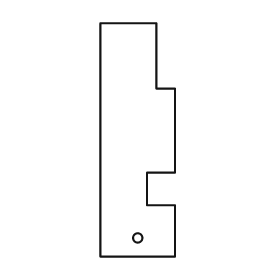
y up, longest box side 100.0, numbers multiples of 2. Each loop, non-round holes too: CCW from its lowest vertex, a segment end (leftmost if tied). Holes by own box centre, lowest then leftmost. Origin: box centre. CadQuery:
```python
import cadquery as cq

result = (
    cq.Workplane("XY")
    .moveTo(-16.0, -50.0)
    .lineTo(16.0, -50.0)
    .lineTo(16.0, -28.0)
    .lineTo(4.0, -28.0)
    .lineTo(4.0, -14.0)
    .lineTo(16.0, -14.0)
    .lineTo(16.0, 22.0)
    .lineTo(8.0, 22.0)
    .lineTo(8.0, 50.0)
    .lineTo(-16.0, 50.0)
    .close()
    .moveTo(0.0, -42.0)
    .circle(2.0)
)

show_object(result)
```